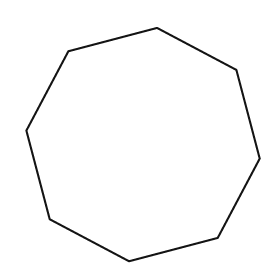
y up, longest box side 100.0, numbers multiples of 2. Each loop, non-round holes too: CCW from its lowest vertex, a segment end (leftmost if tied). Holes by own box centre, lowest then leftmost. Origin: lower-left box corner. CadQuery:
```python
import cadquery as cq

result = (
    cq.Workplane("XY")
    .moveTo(44.0, 0.0)
    .lineTo(82.0, 10.0)
    .lineTo(100.0, 44.0)
    .lineTo(90.0, 82.0)
    .lineTo(56.0, 100.0)
    .lineTo(18.0, 90.0)
    .lineTo(0.0, 56.0)
    .lineTo(10.0, 18.0)
    .close()
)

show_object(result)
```